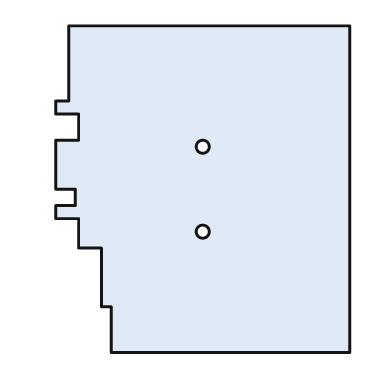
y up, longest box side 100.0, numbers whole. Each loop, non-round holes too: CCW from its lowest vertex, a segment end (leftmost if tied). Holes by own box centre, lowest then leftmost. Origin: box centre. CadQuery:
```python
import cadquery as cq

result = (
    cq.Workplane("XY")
    .moveTo(-28.0, -50.0)
    .lineTo(45.0, -50.0)
    .lineTo(45.0, 50.0)
    .lineTo(-41.0, 50.0)
    .lineTo(-41.0, 27.0)
    .lineTo(-45.0, 27.0)
    .lineTo(-45.0, 23.0)
    .lineTo(-38.0, 23.0)
    .lineTo(-38.0, 15.0)
    .lineTo(-45.0, 15.0)
    .lineTo(-45.0, 0.0)
    .lineTo(-39.0, 0.0)
    .lineTo(-39.0, -5.0)
    .lineTo(-45.0, -5.0)
    .lineTo(-45.0, -9.0)
    .lineTo(-38.0, -9.0)
    .lineTo(-38.0, -18.0)
    .lineTo(-31.0, -18.0)
    .lineTo(-31.0, -36.0)
    .lineTo(-28.0, -36.0)
    .close()
    .moveTo(0.0, -13.0)
    .circle(2.0)
    .moveTo(0.0, 13.0)
    .circle(2.0)
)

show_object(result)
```